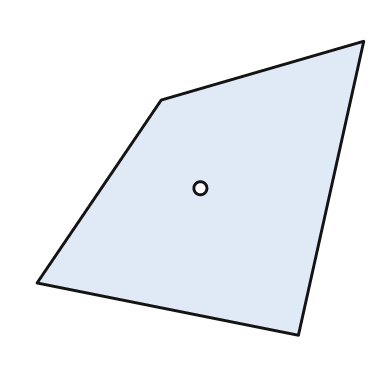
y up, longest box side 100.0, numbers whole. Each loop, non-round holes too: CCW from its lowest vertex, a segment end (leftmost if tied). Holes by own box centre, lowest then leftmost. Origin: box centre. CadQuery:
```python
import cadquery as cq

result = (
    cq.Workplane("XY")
    .moveTo(30.0, -45.0)
    .lineTo(50.0, 45.0)
    .lineTo(-12.0, 27.0)
    .lineTo(-50.0, -29.0)
    .close()
    .moveTo(0.0, 0.0)
    .circle(2.0)
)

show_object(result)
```